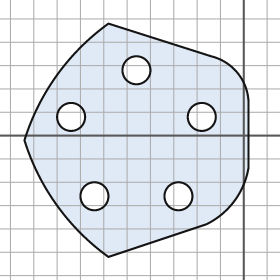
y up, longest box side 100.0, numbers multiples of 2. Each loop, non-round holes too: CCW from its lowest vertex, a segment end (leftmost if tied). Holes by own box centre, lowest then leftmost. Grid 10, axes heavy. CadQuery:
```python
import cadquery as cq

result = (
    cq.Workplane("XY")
    .moveTo(-58.0, -52.0)
    .lineTo(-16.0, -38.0)
    .threePointArc((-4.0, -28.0), (2.0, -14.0))
    .lineTo(2.0, 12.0)
    .threePointArc((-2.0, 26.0), (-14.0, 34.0))
    .lineTo(-58.0, 48.0)
    .threePointArc((-80.0, 26.0), (-94.0, -2.0))
    .threePointArc((-80.0, -30.0), (-58.0, -52.0))
    .close()
    .moveTo(-64.0, -26.0)
    .circle(6.0)
    .moveTo(-28.0, -26.0)
    .circle(6.0)
    .moveTo(-74.0, 8.0)
    .circle(6.0)
    .moveTo(-18.0, 8.0)
    .circle(6.0)
    .moveTo(-46.0, 28.0)
    .circle(6.0)
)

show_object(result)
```